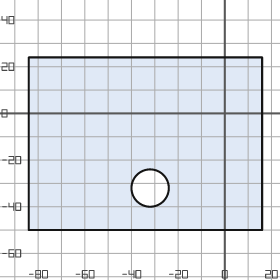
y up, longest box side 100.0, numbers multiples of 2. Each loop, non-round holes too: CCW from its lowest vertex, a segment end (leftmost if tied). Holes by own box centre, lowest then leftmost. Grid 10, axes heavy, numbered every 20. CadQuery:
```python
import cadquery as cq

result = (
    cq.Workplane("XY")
    .moveTo(-84.0, -50.0)
    .lineTo(16.0, -50.0)
    .lineTo(16.0, 24.0)
    .lineTo(-84.0, 24.0)
    .close()
    .moveTo(-32.0, -32.0)
    .circle(8.0)
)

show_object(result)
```